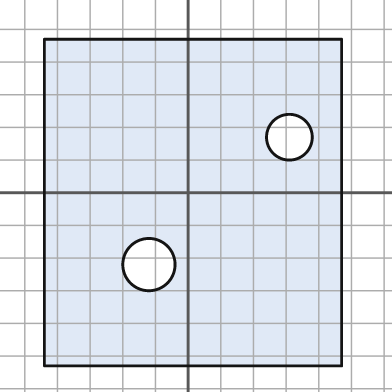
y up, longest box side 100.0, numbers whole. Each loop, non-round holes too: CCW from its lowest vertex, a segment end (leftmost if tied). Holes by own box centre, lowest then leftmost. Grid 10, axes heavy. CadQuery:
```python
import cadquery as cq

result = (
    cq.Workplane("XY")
    .moveTo(-44.0, -53.0)
    .lineTo(47.0, -53.0)
    .lineTo(47.0, 47.0)
    .lineTo(-44.0, 47.0)
    .close()
    .moveTo(-12.0, -22.0)
    .circle(8.0)
    .moveTo(31.0, 17.0)
    .circle(7.0)
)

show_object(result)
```